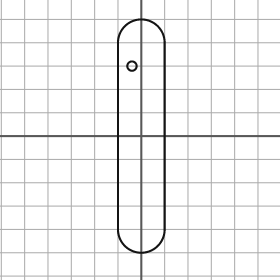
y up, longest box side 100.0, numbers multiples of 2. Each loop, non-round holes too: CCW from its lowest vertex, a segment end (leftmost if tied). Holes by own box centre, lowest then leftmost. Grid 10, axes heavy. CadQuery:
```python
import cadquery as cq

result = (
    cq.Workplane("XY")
    .moveTo(-10.0, -40.0)
    .threePointArc((0.0, -50.0), (10.0, -40.0))
    .lineTo(10.0, 40.0)
    .threePointArc((0.0, 50.0), (-10.0, 40.0))
    .close()
    .moveTo(-4.0, 30.0)
    .circle(2.0)
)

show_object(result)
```